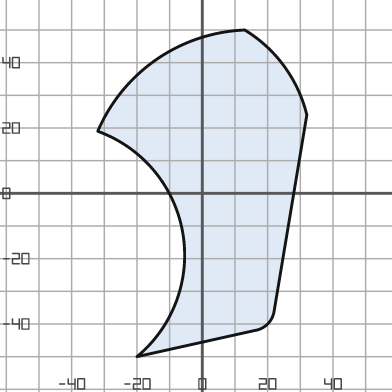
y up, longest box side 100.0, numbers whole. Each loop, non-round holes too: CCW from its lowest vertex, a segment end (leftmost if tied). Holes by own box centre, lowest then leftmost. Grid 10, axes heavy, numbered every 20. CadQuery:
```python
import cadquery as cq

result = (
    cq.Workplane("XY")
    .moveTo(-20.0, -50.0)
    .lineTo(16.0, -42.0)
    .threePointArc((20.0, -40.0), (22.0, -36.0))
    .lineTo(32.0, 24.0)
    .threePointArc((25.0, 39.0), (13.0, 50.0))
    .threePointArc((-14.0, 41.0), (-32.0, 19.0))
    .threePointArc((-6.0, -12.0), (-20.0, -50.0))
    .close()
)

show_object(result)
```